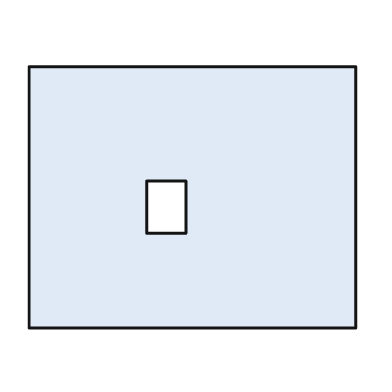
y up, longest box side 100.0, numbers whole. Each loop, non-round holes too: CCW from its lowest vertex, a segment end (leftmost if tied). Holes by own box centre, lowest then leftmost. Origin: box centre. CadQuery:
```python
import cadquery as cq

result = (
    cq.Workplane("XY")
    .moveTo(-50.0, -40.0)
    .lineTo(50.0, -40.0)
    .lineTo(50.0, 40.0)
    .lineTo(-50.0, 40.0)
    .close()
    .moveTo(-14.0, -11.0)
    .lineTo(-2.0, -11.0)
    .lineTo(-2.0, 5.0)
    .lineTo(-14.0, 5.0)
    .close()
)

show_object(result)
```